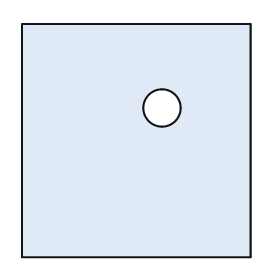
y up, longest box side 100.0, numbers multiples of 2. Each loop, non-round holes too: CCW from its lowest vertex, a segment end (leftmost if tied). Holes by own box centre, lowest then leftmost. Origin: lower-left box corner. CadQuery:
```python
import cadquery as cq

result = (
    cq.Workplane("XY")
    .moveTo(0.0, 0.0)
    .lineTo(98.0, 0.0)
    .lineTo(98.0, 100.0)
    .lineTo(0.0, 100.0)
    .close()
    .moveTo(60.0, 64.0)
    .circle(8.0)
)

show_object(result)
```